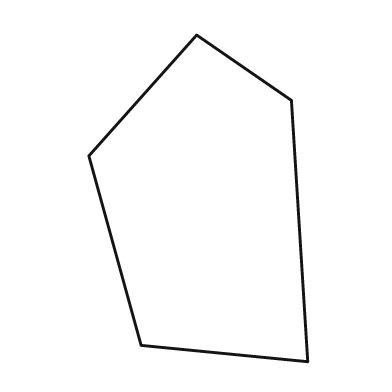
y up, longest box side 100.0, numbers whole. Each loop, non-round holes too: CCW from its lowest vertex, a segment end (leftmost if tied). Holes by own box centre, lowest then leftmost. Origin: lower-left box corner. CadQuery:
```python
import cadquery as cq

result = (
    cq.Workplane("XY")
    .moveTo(67.0, 0.0)
    .lineTo(62.0, 80.0)
    .lineTo(33.0, 100.0)
    .lineTo(0.0, 63.0)
    .lineTo(16.0, 5.0)
    .close()
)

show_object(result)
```